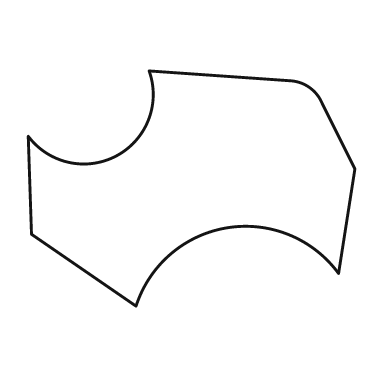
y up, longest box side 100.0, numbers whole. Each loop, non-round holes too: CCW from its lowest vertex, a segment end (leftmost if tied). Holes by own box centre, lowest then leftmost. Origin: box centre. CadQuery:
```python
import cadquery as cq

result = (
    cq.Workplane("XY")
    .moveTo(-17.0, -36.0)
    .threePointArc((11.0, -12.0), (45.0, -26.0))
    .lineTo(50.0, 6.0)
    .lineTo(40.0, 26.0)
    .threePointArc((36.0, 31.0), (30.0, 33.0))
    .lineTo(-13.0, 36.0)
    .threePointArc((-23.0, 10.0), (-50.0, 16.0))
    .lineTo(-49.0, -14.0)
    .close()
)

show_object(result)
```